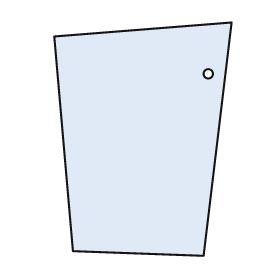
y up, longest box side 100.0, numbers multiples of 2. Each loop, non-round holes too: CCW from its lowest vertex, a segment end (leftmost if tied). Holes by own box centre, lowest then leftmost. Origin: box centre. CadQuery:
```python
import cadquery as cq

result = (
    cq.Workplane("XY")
    .moveTo(26.0, -50.0)
    .lineTo(38.0, 50.0)
    .lineTo(-38.0, 44.0)
    .lineTo(-30.0, -48.0)
    .close()
    .moveTo(28.0, 28.0)
    .circle(2.0)
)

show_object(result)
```